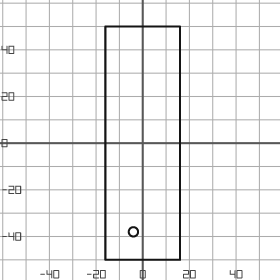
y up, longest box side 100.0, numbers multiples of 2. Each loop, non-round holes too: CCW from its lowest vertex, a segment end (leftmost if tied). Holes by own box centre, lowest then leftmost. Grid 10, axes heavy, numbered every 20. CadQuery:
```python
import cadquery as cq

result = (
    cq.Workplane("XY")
    .moveTo(-16.0, -50.0)
    .lineTo(16.0, -50.0)
    .lineTo(16.0, 50.0)
    .lineTo(-16.0, 50.0)
    .close()
    .moveTo(-4.0, -38.0)
    .circle(2.0)
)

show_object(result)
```